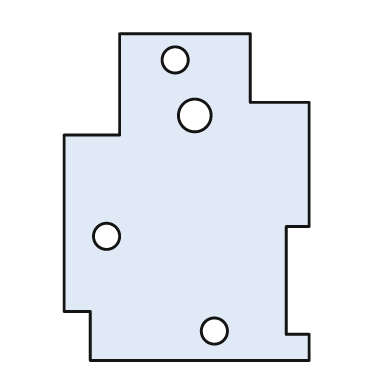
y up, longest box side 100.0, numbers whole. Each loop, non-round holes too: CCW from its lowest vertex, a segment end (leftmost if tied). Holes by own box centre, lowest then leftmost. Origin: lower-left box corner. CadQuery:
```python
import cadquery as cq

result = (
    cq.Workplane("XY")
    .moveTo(8.0, 0.0)
    .lineTo(75.0, 0.0)
    .lineTo(75.0, 8.0)
    .lineTo(68.0, 8.0)
    .lineTo(68.0, 41.0)
    .lineTo(75.0, 41.0)
    .lineTo(75.0, 79.0)
    .lineTo(57.0, 79.0)
    .lineTo(57.0, 100.0)
    .lineTo(17.0, 100.0)
    .lineTo(17.0, 69.0)
    .lineTo(0.0, 69.0)
    .lineTo(0.0, 15.0)
    .lineTo(8.0, 15.0)
    .close()
    .moveTo(46.0, 9.0)
    .circle(4.0)
    .moveTo(13.0, 38.0)
    .circle(4.0)
    .moveTo(40.0, 75.0)
    .circle(5.0)
    .moveTo(34.0, 92.0)
    .circle(4.0)
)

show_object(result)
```